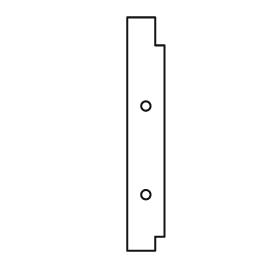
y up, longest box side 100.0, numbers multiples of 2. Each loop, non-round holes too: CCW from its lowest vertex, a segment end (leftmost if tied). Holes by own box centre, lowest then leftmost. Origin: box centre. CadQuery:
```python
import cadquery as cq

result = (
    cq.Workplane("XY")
    .moveTo(-8.0, -50.0)
    .lineTo(4.0, -50.0)
    .lineTo(4.0, -44.0)
    .lineTo(8.0, -44.0)
    .lineTo(8.0, 38.0)
    .lineTo(4.0, 38.0)
    .lineTo(4.0, 50.0)
    .lineTo(-8.0, 50.0)
    .close()
    .moveTo(0.0, -26.0)
    .circle(2.0)
    .moveTo(0.0, 12.0)
    .circle(2.0)
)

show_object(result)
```